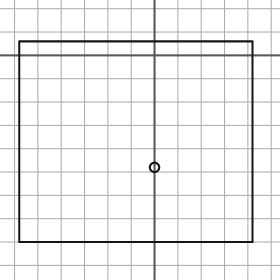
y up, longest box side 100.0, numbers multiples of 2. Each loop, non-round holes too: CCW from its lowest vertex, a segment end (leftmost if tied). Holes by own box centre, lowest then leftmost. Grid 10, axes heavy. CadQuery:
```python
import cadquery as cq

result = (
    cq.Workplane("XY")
    .moveTo(-58.0, -80.0)
    .lineTo(42.0, -80.0)
    .lineTo(42.0, 6.0)
    .lineTo(-58.0, 6.0)
    .close()
    .moveTo(0.0, -48.0)
    .circle(2.0)
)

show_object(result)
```